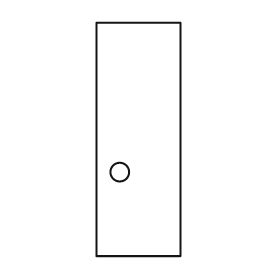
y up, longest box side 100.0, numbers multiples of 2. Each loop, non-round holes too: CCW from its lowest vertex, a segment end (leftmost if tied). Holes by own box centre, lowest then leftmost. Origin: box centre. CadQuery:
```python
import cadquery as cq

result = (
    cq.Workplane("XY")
    .moveTo(-18.0, -50.0)
    .lineTo(18.0, -50.0)
    .lineTo(18.0, 50.0)
    .lineTo(-18.0, 50.0)
    .close()
    .moveTo(-8.0, -14.0)
    .circle(4.0)
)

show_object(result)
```